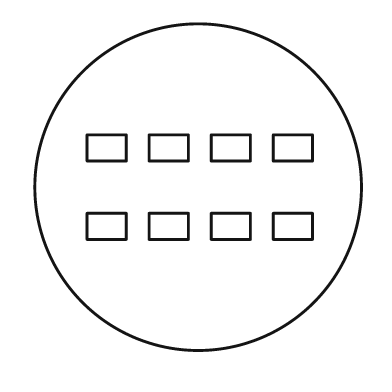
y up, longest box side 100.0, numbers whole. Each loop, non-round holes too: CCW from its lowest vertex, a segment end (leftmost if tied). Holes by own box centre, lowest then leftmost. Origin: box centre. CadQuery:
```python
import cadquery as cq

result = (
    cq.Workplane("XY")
    .moveTo(0.0, 0.0)
    .circle(50.0)
    .moveTo(-34.0, -16.0)
    .lineTo(-22.0, -16.0)
    .lineTo(-22.0, -8.0)
    .lineTo(-34.0, -8.0)
    .close()
    .moveTo(-15.0, -16.0)
    .lineTo(-3.0, -16.0)
    .lineTo(-3.0, -8.0)
    .lineTo(-15.0, -8.0)
    .close()
    .moveTo(4.0, -16.0)
    .lineTo(16.0, -16.0)
    .lineTo(16.0, -8.0)
    .lineTo(4.0, -8.0)
    .close()
    .moveTo(23.0, -16.0)
    .lineTo(35.0, -16.0)
    .lineTo(35.0, -8.0)
    .lineTo(23.0, -8.0)
    .close()
    .moveTo(-34.0, 8.0)
    .lineTo(-22.0, 8.0)
    .lineTo(-22.0, 16.0)
    .lineTo(-34.0, 16.0)
    .close()
    .moveTo(-15.0, 8.0)
    .lineTo(-3.0, 8.0)
    .lineTo(-3.0, 16.0)
    .lineTo(-15.0, 16.0)
    .close()
    .moveTo(4.0, 8.0)
    .lineTo(16.0, 8.0)
    .lineTo(16.0, 16.0)
    .lineTo(4.0, 16.0)
    .close()
    .moveTo(23.0, 8.0)
    .lineTo(35.0, 8.0)
    .lineTo(35.0, 16.0)
    .lineTo(23.0, 16.0)
    .close()
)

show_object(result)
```